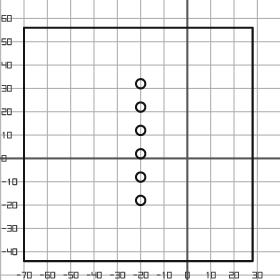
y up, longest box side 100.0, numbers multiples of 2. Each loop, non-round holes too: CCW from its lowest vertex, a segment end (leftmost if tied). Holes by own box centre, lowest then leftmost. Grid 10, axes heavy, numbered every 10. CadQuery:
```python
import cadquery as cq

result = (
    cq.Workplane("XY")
    .moveTo(-70.0, -44.0)
    .lineTo(28.0, -44.0)
    .lineTo(28.0, 56.0)
    .lineTo(-70.0, 56.0)
    .close()
    .moveTo(-20.0, -18.0)
    .circle(2.0)
    .moveTo(-20.0, -8.0)
    .circle(2.0)
    .moveTo(-20.0, 2.0)
    .circle(2.0)
    .moveTo(-20.0, 12.0)
    .circle(2.0)
    .moveTo(-20.0, 22.0)
    .circle(2.0)
    .moveTo(-20.0, 32.0)
    .circle(2.0)
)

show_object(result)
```